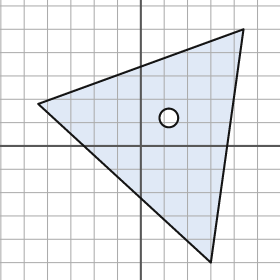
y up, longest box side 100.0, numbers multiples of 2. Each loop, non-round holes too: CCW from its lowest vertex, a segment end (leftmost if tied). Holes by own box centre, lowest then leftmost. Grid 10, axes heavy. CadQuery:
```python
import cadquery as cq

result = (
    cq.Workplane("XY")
    .moveTo(30.0, -50.0)
    .lineTo(44.0, 50.0)
    .lineTo(-44.0, 18.0)
    .close()
    .moveTo(12.0, 12.0)
    .circle(4.0)
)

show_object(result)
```